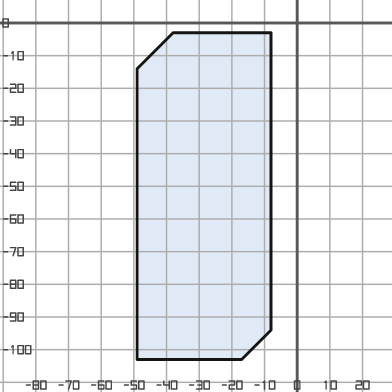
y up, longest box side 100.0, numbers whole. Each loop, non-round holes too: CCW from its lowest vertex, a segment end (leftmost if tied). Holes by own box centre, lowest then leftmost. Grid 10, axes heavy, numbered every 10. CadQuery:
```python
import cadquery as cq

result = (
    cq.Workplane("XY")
    .moveTo(-49.0, -103.0)
    .lineTo(-17.0, -103.0)
    .lineTo(-8.0, -94.0)
    .lineTo(-8.0, -3.0)
    .lineTo(-38.0, -3.0)
    .lineTo(-49.0, -14.0)
    .close()
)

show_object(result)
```